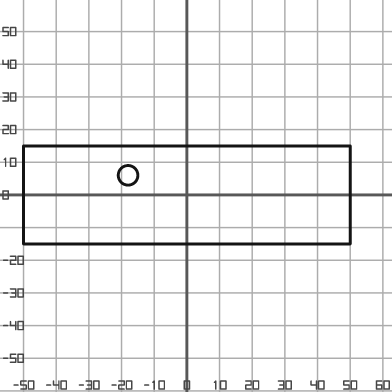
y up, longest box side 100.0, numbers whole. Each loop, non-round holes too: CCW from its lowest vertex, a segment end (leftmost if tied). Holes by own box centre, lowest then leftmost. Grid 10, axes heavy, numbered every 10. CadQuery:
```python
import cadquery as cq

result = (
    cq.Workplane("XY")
    .moveTo(-50.0, -15.0)
    .lineTo(50.0, -15.0)
    .lineTo(50.0, 15.0)
    .lineTo(-50.0, 15.0)
    .close()
    .moveTo(-18.0, 6.0)
    .circle(3.0)
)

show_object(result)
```